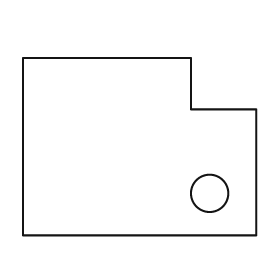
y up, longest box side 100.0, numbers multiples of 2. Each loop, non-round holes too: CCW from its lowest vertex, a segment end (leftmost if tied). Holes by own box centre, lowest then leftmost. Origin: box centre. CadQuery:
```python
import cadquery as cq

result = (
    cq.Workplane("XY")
    .moveTo(-50.0, -38.0)
    .lineTo(50.0, -38.0)
    .lineTo(50.0, 16.0)
    .lineTo(22.0, 16.0)
    .lineTo(22.0, 38.0)
    .lineTo(-50.0, 38.0)
    .close()
    .moveTo(30.0, -20.0)
    .circle(8.0)
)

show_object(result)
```